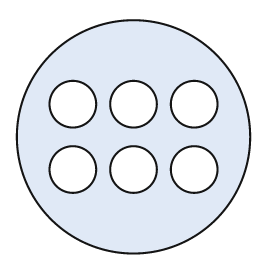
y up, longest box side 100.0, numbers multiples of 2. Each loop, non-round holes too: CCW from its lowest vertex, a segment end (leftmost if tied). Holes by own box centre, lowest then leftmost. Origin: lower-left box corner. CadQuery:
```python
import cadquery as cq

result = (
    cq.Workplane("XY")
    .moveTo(50.0, 50.0)
    .circle(50.0)
    .moveTo(24.0, 36.0)
    .circle(10.0)
    .moveTo(50.0, 36.0)
    .circle(10.0)
    .moveTo(76.0, 36.0)
    .circle(10.0)
    .moveTo(24.0, 64.0)
    .circle(10.0)
    .moveTo(50.0, 64.0)
    .circle(10.0)
    .moveTo(76.0, 64.0)
    .circle(10.0)
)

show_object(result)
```